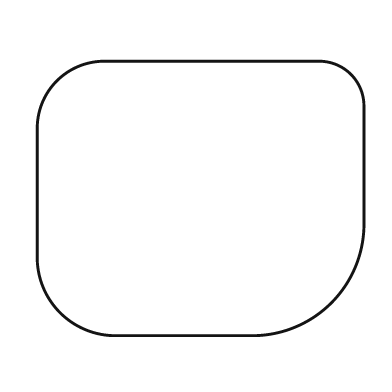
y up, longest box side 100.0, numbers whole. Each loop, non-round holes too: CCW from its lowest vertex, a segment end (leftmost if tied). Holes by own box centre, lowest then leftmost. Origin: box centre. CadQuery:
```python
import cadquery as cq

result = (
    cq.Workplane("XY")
    .moveTo(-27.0, -42.0)
    .lineTo(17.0, -42.0)
    .threePointArc((40.0, -32.0), (50.0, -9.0))
    .lineTo(50.0, 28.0)
    .threePointArc((46.0, 38.0), (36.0, 42.0))
    .lineTo(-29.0, 42.0)
    .threePointArc((-44.0, 36.0), (-50.0, 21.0))
    .lineTo(-50.0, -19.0)
    .threePointArc((-43.0, -35.0), (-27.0, -42.0))
    .close()
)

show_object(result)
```